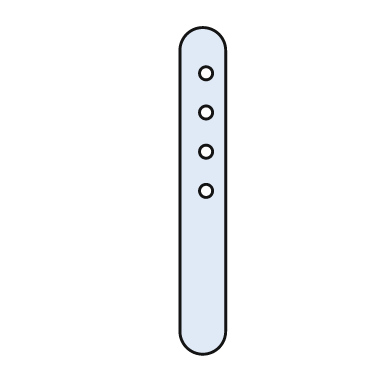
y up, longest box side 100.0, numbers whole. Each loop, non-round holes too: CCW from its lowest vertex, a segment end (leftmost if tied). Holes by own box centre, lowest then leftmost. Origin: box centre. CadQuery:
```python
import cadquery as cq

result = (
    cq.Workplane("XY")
    .moveTo(-7.0, -43.0)
    .threePointArc((0.0, -50.0), (7.0, -43.0))
    .lineTo(7.0, 43.0)
    .threePointArc((0.0, 50.0), (-7.0, 43.0))
    .close()
    .moveTo(1.0, 0.0)
    .circle(2.0)
    .moveTo(1.0, 12.0)
    .circle(2.0)
    .moveTo(1.0, 24.0)
    .circle(2.0)
    .moveTo(1.0, 36.0)
    .circle(2.0)
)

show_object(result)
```